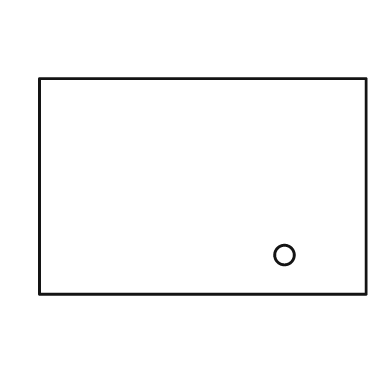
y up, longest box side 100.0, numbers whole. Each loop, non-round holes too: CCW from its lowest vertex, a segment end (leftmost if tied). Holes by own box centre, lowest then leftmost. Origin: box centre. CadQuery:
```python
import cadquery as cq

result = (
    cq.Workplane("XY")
    .moveTo(-50.0, -33.0)
    .lineTo(50.0, -33.0)
    .lineTo(50.0, 33.0)
    .lineTo(-50.0, 33.0)
    .close()
    .moveTo(25.0, -21.0)
    .circle(3.0)
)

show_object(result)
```